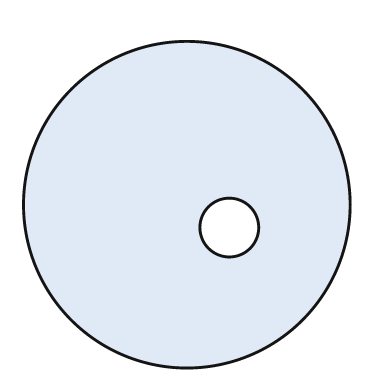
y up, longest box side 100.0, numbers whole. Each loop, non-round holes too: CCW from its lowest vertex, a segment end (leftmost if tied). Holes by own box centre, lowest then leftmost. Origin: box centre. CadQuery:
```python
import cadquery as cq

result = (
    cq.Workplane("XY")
    .moveTo(0.0, 0.0)
    .circle(50.0)
    .moveTo(13.0, -7.0)
    .circle(9.0)
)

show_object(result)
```